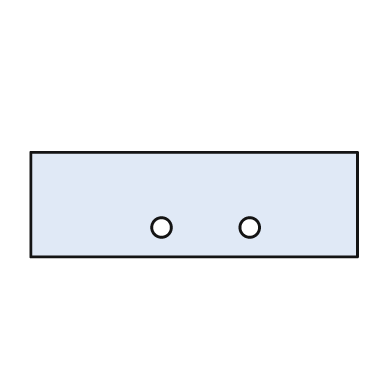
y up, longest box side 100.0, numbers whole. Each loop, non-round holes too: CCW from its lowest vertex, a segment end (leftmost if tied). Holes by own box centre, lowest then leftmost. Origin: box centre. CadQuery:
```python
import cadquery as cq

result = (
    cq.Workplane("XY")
    .moveTo(-50.0, -16.0)
    .lineTo(50.0, -16.0)
    .lineTo(50.0, 16.0)
    .lineTo(-50.0, 16.0)
    .close()
    .moveTo(-10.0, -7.0)
    .circle(3.0)
    .moveTo(17.0, -7.0)
    .circle(3.0)
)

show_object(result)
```